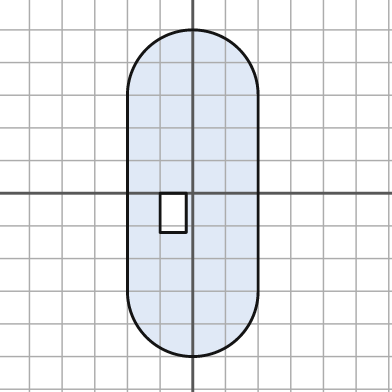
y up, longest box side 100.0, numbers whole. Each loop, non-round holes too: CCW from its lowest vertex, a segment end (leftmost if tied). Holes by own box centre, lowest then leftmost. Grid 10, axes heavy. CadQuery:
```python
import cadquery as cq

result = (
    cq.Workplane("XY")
    .moveTo(-20.0, -30.0)
    .threePointArc((0.0, -50.0), (20.0, -30.0))
    .lineTo(20.0, 30.0)
    .threePointArc((0.0, 50.0), (-20.0, 30.0))
    .close()
    .moveTo(-10.0, -12.0)
    .lineTo(-2.0, -12.0)
    .lineTo(-2.0, 0.0)
    .lineTo(-10.0, 0.0)
    .close()
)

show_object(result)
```